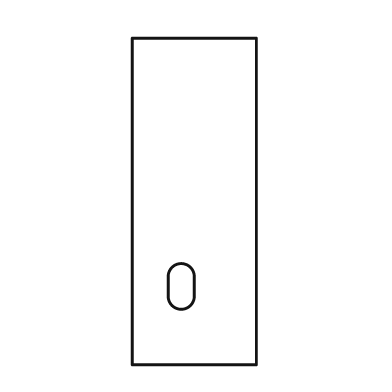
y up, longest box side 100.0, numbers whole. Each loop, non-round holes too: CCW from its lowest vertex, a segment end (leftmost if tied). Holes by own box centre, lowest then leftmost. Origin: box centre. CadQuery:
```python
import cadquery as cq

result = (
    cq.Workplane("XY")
    .moveTo(-19.0, -50.0)
    .lineTo(19.0, -50.0)
    .lineTo(19.0, 50.0)
    .lineTo(-19.0, 50.0)
    .close()
    .moveTo(-8.0, -29.0)
    .threePointArc((-4.0, -33.0), (0.0, -29.0))
    .lineTo(0.0, -23.0)
    .threePointArc((-4.0, -19.0), (-8.0, -23.0))
    .close()
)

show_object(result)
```